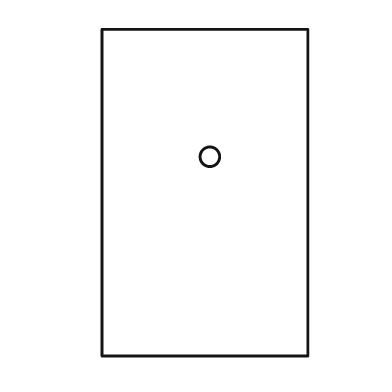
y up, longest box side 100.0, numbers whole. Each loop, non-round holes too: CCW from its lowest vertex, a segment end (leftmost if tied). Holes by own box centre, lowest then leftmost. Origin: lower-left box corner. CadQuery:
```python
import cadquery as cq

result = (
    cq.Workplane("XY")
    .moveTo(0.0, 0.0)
    .lineTo(63.0, 0.0)
    .lineTo(63.0, 100.0)
    .lineTo(0.0, 100.0)
    .close()
    .moveTo(33.0, 61.0)
    .circle(3.0)
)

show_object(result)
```